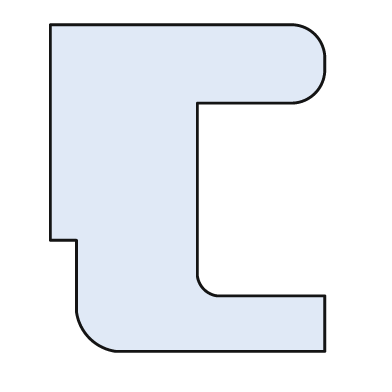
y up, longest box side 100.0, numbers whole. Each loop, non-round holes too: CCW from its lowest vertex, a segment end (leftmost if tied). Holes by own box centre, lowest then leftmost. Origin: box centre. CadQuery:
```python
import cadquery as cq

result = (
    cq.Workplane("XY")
    .moveTo(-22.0, -50.0)
    .lineTo(42.0, -50.0)
    .lineTo(42.0, -33.0)
    .lineTo(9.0, -33.0)
    .threePointArc((5.0, -31.0), (3.0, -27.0))
    .lineTo(3.0, 26.0)
    .lineTo(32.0, 26.0)
    .threePointArc((39.0, 29.0), (42.0, 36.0))
    .lineTo(42.0, 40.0)
    .threePointArc((39.0, 47.0), (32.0, 50.0))
    .lineTo(-42.0, 50.0)
    .lineTo(-42.0, -16.0)
    .lineTo(-34.0, -16.0)
    .lineTo(-34.0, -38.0)
    .threePointArc((-30.0, -46.0), (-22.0, -50.0))
    .close()
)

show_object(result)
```